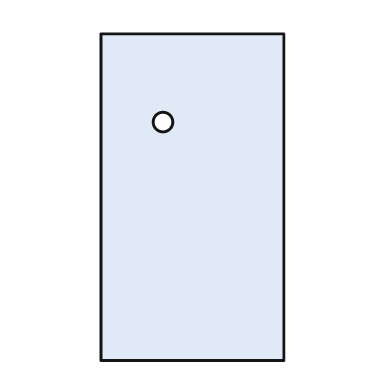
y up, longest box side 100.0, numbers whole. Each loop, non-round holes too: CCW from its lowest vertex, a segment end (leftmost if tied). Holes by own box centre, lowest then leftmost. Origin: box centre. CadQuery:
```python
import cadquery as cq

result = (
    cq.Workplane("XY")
    .moveTo(-28.0, -50.0)
    .lineTo(28.0, -50.0)
    .lineTo(28.0, 50.0)
    .lineTo(-28.0, 50.0)
    .close()
    .moveTo(-9.0, 23.0)
    .circle(3.0)
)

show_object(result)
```